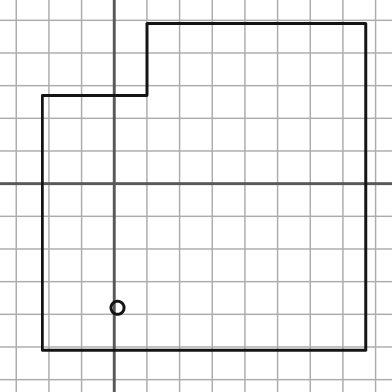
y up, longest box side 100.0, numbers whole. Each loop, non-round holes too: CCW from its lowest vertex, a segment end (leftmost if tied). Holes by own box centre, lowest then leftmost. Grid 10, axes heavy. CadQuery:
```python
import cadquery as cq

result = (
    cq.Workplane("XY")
    .moveTo(-22.0, -51.0)
    .lineTo(77.0, -51.0)
    .lineTo(77.0, 49.0)
    .lineTo(10.0, 49.0)
    .lineTo(10.0, 27.0)
    .lineTo(-22.0, 27.0)
    .close()
    .moveTo(1.0, -38.0)
    .circle(2.0)
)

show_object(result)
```